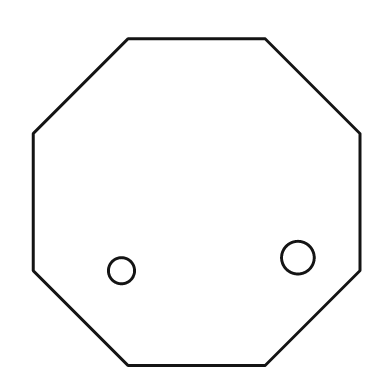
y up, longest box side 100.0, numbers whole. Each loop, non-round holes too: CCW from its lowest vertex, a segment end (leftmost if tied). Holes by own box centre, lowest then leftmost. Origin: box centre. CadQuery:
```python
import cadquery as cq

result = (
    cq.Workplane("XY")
    .moveTo(-21.0, -50.0)
    .lineTo(21.0, -50.0)
    .lineTo(50.0, -21.0)
    .lineTo(50.0, 21.0)
    .lineTo(21.0, 50.0)
    .lineTo(-21.0, 50.0)
    .lineTo(-50.0, 21.0)
    .lineTo(-50.0, -21.0)
    .close()
    .moveTo(-23.0, -21.0)
    .circle(4.0)
    .moveTo(31.0, -17.0)
    .circle(5.0)
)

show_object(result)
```